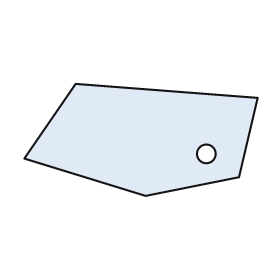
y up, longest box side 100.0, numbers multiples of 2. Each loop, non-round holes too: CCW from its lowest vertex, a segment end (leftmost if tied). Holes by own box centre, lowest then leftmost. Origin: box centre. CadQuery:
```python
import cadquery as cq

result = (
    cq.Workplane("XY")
    .moveTo(2.0, -24.0)
    .lineTo(42.0, -16.0)
    .lineTo(50.0, 18.0)
    .lineTo(-28.0, 24.0)
    .lineTo(-50.0, -8.0)
    .close()
    .moveTo(28.0, -6.0)
    .circle(4.0)
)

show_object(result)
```